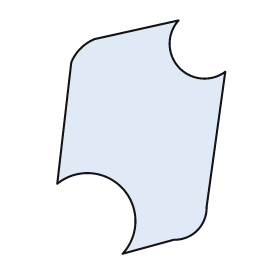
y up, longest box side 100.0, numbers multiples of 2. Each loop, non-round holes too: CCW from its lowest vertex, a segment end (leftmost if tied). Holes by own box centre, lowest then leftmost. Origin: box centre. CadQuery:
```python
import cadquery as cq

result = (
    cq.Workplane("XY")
    .moveTo(-8.0, -50.0)
    .lineTo(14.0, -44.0)
    .threePointArc((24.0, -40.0), (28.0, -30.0))
    .lineTo(36.0, 28.0)
    .threePointArc((16.0, 30.0), (16.0, 50.0))
    .lineTo(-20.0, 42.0)
    .threePointArc((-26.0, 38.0), (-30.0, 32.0))
    .lineTo(-36.0, -20.0)
    .threePointArc((-8.0, -22.0), (-8.0, -50.0))
    .close()
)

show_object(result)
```